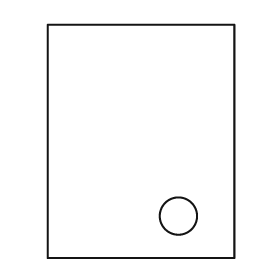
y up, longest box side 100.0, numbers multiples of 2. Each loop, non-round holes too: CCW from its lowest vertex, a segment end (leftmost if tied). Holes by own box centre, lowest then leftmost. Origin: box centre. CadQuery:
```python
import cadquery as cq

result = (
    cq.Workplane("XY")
    .moveTo(-40.0, -50.0)
    .lineTo(40.0, -50.0)
    .lineTo(40.0, 50.0)
    .lineTo(-40.0, 50.0)
    .close()
    .moveTo(16.0, -32.0)
    .circle(8.0)
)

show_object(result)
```